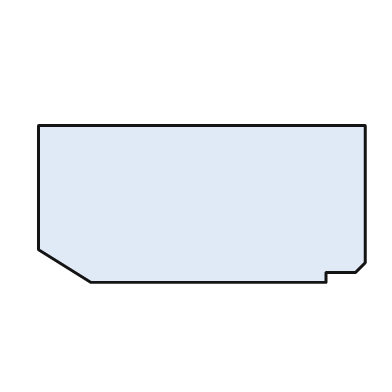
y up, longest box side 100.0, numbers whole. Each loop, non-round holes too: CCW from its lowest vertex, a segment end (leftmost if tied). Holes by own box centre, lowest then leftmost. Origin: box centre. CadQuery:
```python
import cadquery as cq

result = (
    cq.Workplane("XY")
    .moveTo(-34.0, -24.0)
    .lineTo(38.0, -24.0)
    .lineTo(38.0, -21.0)
    .lineTo(47.0, -21.0)
    .lineTo(50.0, -18.0)
    .lineTo(50.0, 24.0)
    .lineTo(-50.0, 24.0)
    .lineTo(-50.0, -14.0)
    .close()
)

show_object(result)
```